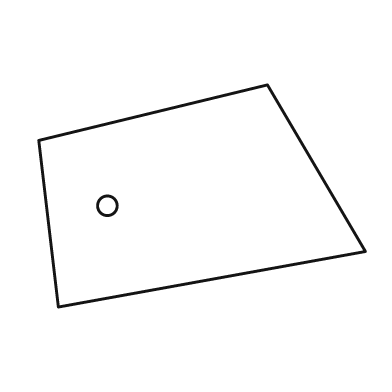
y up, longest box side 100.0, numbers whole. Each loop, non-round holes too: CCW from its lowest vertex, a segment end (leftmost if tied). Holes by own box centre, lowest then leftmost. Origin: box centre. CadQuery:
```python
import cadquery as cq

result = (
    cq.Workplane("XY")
    .moveTo(-44.0, -34.0)
    .lineTo(50.0, -17.0)
    .lineTo(20.0, 34.0)
    .lineTo(-50.0, 17.0)
    .close()
    .moveTo(-29.0, -3.0)
    .circle(3.0)
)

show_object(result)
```